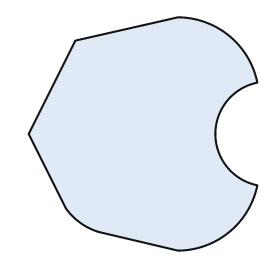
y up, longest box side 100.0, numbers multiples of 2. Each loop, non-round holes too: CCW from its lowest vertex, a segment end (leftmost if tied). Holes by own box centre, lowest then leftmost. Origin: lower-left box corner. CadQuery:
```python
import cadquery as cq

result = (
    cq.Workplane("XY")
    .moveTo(64.0, 0.0)
    .threePointArc((86.0, 8.0), (98.0, 28.0))
    .threePointArc((80.0, 50.0), (98.0, 72.0))
    .threePointArc((86.0, 92.0), (64.0, 100.0))
    .lineTo(20.0, 90.0)
    .lineTo(0.0, 50.0)
    .lineTo(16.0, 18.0)
    .threePointArc((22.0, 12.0), (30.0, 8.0))
    .close()
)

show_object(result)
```